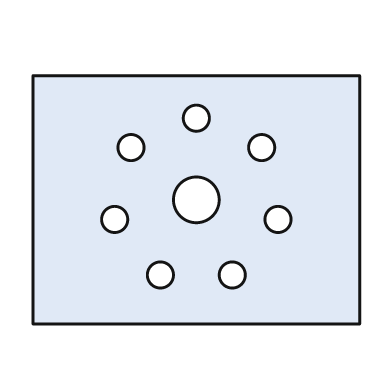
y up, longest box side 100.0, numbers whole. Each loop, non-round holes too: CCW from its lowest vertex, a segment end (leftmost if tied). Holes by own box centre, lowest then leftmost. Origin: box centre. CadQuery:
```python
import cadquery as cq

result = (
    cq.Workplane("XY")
    .moveTo(-50.0, -38.0)
    .lineTo(50.0, -38.0)
    .lineTo(50.0, 38.0)
    .lineTo(-50.0, 38.0)
    .close()
    .moveTo(-11.0, -23.0)
    .circle(4.0)
    .moveTo(11.0, -23.0)
    .circle(4.0)
    .moveTo(-25.0, -6.0)
    .circle(4.0)
    .moveTo(25.0, -6.0)
    .circle(4.0)
    .moveTo(0.0, 0.0)
    .circle(7.0)
    .moveTo(-20.0, 16.0)
    .circle(4.0)
    .moveTo(20.0, 16.0)
    .circle(4.0)
    .moveTo(0.0, 25.0)
    .circle(4.0)
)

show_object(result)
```